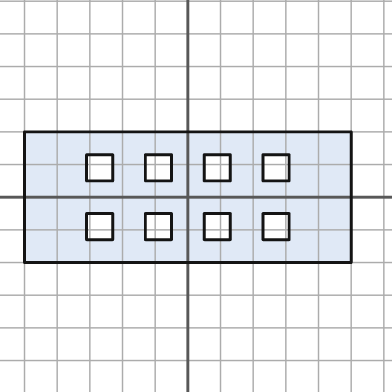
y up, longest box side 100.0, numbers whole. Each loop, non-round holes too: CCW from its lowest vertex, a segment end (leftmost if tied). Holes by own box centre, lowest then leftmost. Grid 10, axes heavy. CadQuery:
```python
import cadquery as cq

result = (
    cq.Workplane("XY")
    .moveTo(-50.0, -20.0)
    .lineTo(50.0, -20.0)
    .lineTo(50.0, 20.0)
    .lineTo(-50.0, 20.0)
    .close()
    .moveTo(-31.0, -13.0)
    .lineTo(-23.0, -13.0)
    .lineTo(-23.0, -5.0)
    .lineTo(-31.0, -5.0)
    .close()
    .moveTo(-13.0, -13.0)
    .lineTo(-5.0, -13.0)
    .lineTo(-5.0, -5.0)
    .lineTo(-13.0, -5.0)
    .close()
    .moveTo(5.0, -13.0)
    .lineTo(13.0, -13.0)
    .lineTo(13.0, -5.0)
    .lineTo(5.0, -5.0)
    .close()
    .moveTo(23.0, -13.0)
    .lineTo(31.0, -13.0)
    .lineTo(31.0, -5.0)
    .lineTo(23.0, -5.0)
    .close()
    .moveTo(-31.0, 5.0)
    .lineTo(-23.0, 5.0)
    .lineTo(-23.0, 13.0)
    .lineTo(-31.0, 13.0)
    .close()
    .moveTo(-13.0, 5.0)
    .lineTo(-5.0, 5.0)
    .lineTo(-5.0, 13.0)
    .lineTo(-13.0, 13.0)
    .close()
    .moveTo(5.0, 5.0)
    .lineTo(13.0, 5.0)
    .lineTo(13.0, 13.0)
    .lineTo(5.0, 13.0)
    .close()
    .moveTo(23.0, 5.0)
    .lineTo(31.0, 5.0)
    .lineTo(31.0, 13.0)
    .lineTo(23.0, 13.0)
    .close()
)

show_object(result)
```